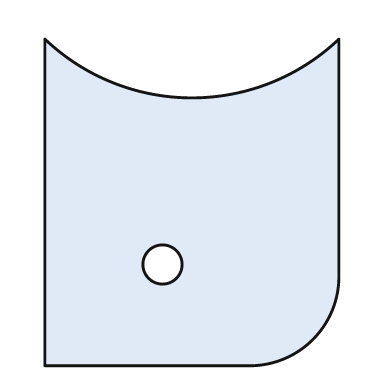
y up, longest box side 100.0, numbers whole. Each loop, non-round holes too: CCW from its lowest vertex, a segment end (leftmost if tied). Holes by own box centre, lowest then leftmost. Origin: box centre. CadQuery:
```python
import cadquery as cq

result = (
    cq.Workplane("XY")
    .moveTo(-45.0, -50.0)
    .lineTo(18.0, -50.0)
    .threePointArc((37.0, -42.0), (45.0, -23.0))
    .lineTo(45.0, 50.0)
    .threePointArc((0.0, 32.0), (-45.0, 50.0))
    .close()
    .moveTo(-9.0, -19.0)
    .circle(6.0)
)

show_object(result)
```